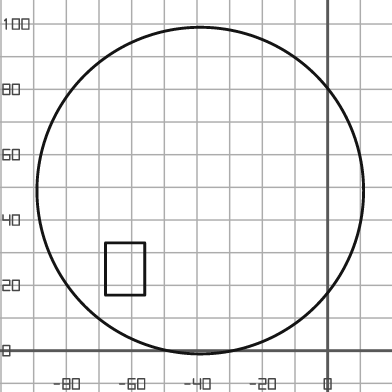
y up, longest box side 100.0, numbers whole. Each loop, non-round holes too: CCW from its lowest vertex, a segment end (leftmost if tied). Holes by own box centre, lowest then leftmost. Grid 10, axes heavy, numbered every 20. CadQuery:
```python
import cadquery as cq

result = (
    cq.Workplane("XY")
    .moveTo(-39.0, 49.0)
    .circle(50.0)
    .moveTo(-68.0, 17.0)
    .lineTo(-56.0, 17.0)
    .lineTo(-56.0, 33.0)
    .lineTo(-68.0, 33.0)
    .close()
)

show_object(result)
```